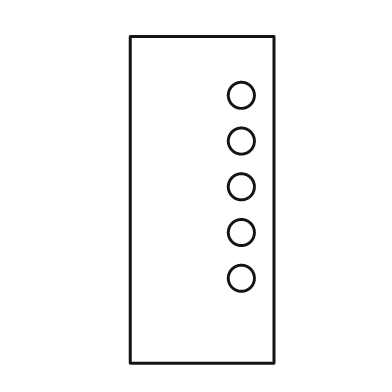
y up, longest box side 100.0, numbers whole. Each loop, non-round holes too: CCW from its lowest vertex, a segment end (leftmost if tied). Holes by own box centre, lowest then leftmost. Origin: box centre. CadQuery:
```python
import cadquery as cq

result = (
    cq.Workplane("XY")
    .moveTo(-22.0, -50.0)
    .lineTo(22.0, -50.0)
    .lineTo(22.0, 50.0)
    .lineTo(-22.0, 50.0)
    .close()
    .moveTo(12.0, -24.0)
    .circle(4.0)
    .moveTo(12.0, -10.0)
    .circle(4.0)
    .moveTo(12.0, 4.0)
    .circle(4.0)
    .moveTo(12.0, 18.0)
    .circle(4.0)
    .moveTo(12.0, 32.0)
    .circle(4.0)
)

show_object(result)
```